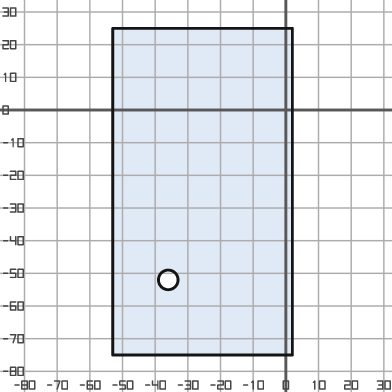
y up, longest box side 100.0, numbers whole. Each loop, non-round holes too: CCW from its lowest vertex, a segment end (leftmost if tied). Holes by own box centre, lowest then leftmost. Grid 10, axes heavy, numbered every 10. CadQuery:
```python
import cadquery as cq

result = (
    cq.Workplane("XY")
    .moveTo(-53.0, -75.0)
    .lineTo(2.0, -75.0)
    .lineTo(2.0, 25.0)
    .lineTo(-53.0, 25.0)
    .close()
    .moveTo(-36.0, -52.0)
    .circle(3.0)
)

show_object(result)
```